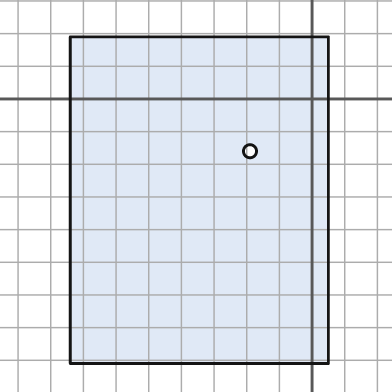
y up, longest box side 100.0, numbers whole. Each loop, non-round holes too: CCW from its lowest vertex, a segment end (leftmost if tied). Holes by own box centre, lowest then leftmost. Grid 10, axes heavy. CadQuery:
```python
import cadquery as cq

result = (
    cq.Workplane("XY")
    .moveTo(-74.0, -81.0)
    .lineTo(5.0, -81.0)
    .lineTo(5.0, 19.0)
    .lineTo(-74.0, 19.0)
    .close()
    .moveTo(-19.0, -16.0)
    .circle(2.0)
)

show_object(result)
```